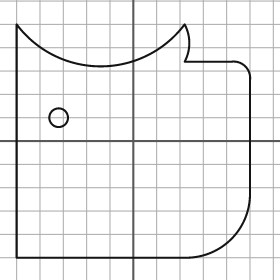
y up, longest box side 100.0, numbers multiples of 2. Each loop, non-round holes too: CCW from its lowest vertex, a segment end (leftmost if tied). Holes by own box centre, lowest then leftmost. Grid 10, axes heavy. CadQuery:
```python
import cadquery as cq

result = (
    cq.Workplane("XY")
    .moveTo(-50.0, -50.0)
    .lineTo(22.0, -50.0)
    .threePointArc((42.0, -42.0), (50.0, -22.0))
    .lineTo(50.0, 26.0)
    .threePointArc((48.0, 32.0), (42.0, 34.0))
    .lineTo(22.0, 34.0)
    .threePointArc((24.0, 42.0), (22.0, 50.0))
    .threePointArc((-14.0, 32.0), (-50.0, 50.0))
    .close()
    .moveTo(-32.0, 10.0)
    .circle(4.0)
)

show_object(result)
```